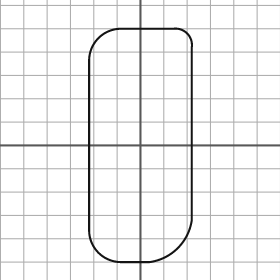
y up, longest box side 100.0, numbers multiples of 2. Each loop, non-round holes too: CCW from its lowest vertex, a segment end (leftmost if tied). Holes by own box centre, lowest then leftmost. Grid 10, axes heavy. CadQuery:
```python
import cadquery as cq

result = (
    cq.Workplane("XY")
    .moveTo(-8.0, -50.0)
    .lineTo(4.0, -50.0)
    .threePointArc((16.0, -44.0), (22.0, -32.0))
    .lineTo(22.0, 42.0)
    .threePointArc((20.0, 48.0), (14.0, 50.0))
    .lineTo(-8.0, 50.0)
    .threePointArc((-18.0, 46.0), (-22.0, 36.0))
    .lineTo(-22.0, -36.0)
    .threePointArc((-18.0, -46.0), (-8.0, -50.0))
    .close()
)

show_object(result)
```